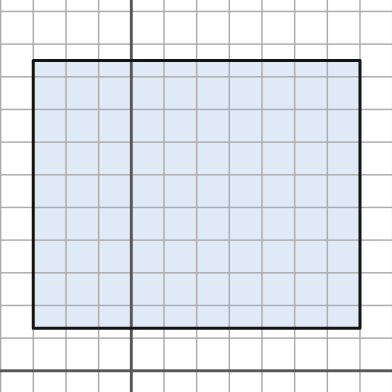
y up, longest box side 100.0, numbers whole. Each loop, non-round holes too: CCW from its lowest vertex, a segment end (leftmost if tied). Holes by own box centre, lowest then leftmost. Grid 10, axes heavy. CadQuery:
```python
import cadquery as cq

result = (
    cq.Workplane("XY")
    .moveTo(-30.0, 13.0)
    .lineTo(70.0, 13.0)
    .lineTo(70.0, 95.0)
    .lineTo(-30.0, 95.0)
    .close()
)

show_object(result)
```